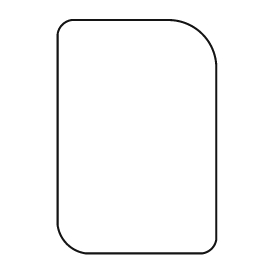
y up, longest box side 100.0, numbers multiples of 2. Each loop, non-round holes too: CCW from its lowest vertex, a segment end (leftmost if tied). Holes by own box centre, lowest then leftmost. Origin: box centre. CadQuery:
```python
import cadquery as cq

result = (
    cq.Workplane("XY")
    .moveTo(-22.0, -50.0)
    .lineTo(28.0, -50.0)
    .threePointArc((32.0, -48.0), (34.0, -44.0))
    .lineTo(34.0, 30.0)
    .threePointArc((28.0, 44.0), (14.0, 50.0))
    .lineTo(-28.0, 50.0)
    .threePointArc((-32.0, 48.0), (-34.0, 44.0))
    .lineTo(-34.0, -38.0)
    .threePointArc((-30.0, -46.0), (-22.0, -50.0))
    .close()
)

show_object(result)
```